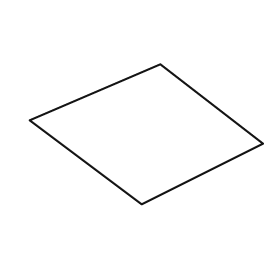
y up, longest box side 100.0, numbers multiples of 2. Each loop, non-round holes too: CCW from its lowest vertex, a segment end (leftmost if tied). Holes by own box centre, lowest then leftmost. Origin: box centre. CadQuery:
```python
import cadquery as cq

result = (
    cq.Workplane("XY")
    .moveTo(-2.0, -30.0)
    .lineTo(50.0, -4.0)
    .lineTo(6.0, 30.0)
    .lineTo(-50.0, 6.0)
    .close()
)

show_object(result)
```